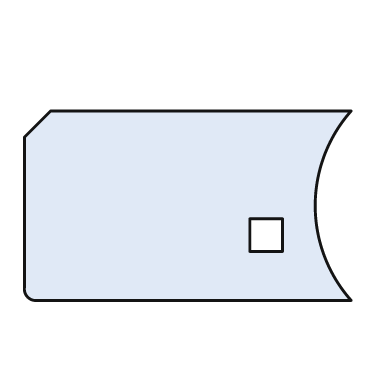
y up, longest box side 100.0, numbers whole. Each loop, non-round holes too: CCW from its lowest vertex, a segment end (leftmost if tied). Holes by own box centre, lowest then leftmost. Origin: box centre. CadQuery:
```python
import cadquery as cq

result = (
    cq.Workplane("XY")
    .moveTo(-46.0, -29.0)
    .lineTo(50.0, -29.0)
    .threePointArc((39.0, 0.0), (50.0, 29.0))
    .lineTo(-42.0, 29.0)
    .lineTo(-50.0, 21.0)
    .lineTo(-50.0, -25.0)
    .threePointArc((-49.0, -28.0), (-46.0, -29.0))
    .close()
    .moveTo(19.0, -14.0)
    .lineTo(29.0, -14.0)
    .lineTo(29.0, -4.0)
    .lineTo(19.0, -4.0)
    .close()
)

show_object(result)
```